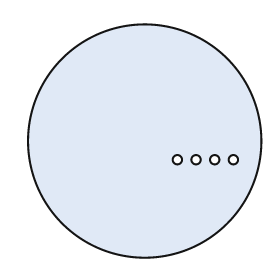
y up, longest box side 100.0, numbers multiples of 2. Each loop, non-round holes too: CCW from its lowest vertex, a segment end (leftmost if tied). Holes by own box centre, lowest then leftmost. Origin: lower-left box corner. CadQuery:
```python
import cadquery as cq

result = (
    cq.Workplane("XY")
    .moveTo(50.0, 50.0)
    .circle(50.0)
    .moveTo(64.0, 42.0)
    .circle(2.0)
    .moveTo(72.0, 42.0)
    .circle(2.0)
    .moveTo(80.0, 42.0)
    .circle(2.0)
    .moveTo(88.0, 42.0)
    .circle(2.0)
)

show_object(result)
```